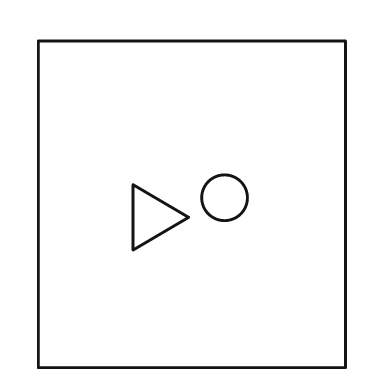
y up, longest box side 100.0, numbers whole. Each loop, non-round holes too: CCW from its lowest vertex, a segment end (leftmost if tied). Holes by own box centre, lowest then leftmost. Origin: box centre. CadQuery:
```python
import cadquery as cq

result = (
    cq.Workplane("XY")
    .moveTo(-47.0, -50.0)
    .lineTo(47.0, -50.0)
    .lineTo(47.0, 50.0)
    .lineTo(-47.0, 50.0)
    .close()
    .moveTo(-18.0, -14.0)
    .lineTo(-1.0, -4.0)
    .lineTo(-18.0, 6.0)
    .close()
    .moveTo(10.0, 2.0)
    .circle(7.0)
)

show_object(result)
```